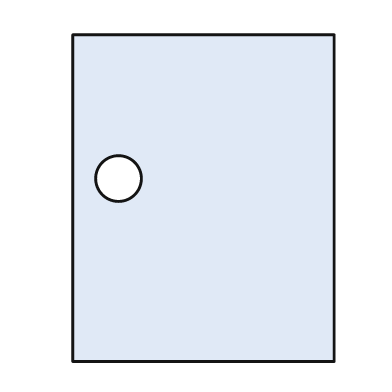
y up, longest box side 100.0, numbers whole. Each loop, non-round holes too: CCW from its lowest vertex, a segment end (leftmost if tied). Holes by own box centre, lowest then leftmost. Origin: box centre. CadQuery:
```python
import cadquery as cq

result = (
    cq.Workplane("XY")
    .moveTo(-40.0, -50.0)
    .lineTo(40.0, -50.0)
    .lineTo(40.0, 50.0)
    .lineTo(-40.0, 50.0)
    .close()
    .moveTo(-26.0, 6.0)
    .circle(7.0)
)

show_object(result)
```